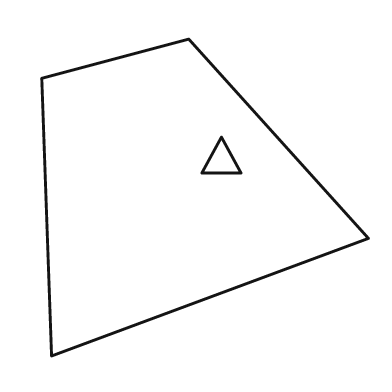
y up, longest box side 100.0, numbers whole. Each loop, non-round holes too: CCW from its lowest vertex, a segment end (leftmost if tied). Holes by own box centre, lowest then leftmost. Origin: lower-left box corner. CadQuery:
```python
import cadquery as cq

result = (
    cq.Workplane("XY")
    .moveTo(3.0, 0.0)
    .lineTo(100.0, 36.0)
    .lineTo(45.0, 97.0)
    .lineTo(0.0, 85.0)
    .close()
    .moveTo(49.0, 56.0)
    .lineTo(61.0, 56.0)
    .lineTo(55.0, 67.0)
    .close()
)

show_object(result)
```